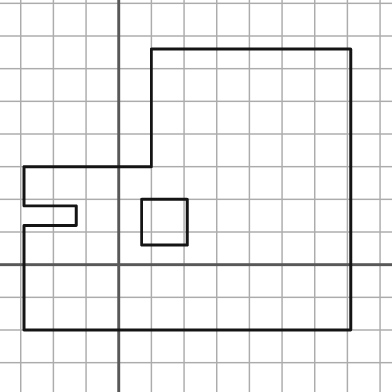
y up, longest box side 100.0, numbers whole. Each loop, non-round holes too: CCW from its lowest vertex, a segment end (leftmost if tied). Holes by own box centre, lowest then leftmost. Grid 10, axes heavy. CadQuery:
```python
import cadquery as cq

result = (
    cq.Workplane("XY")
    .moveTo(-29.0, -20.0)
    .lineTo(71.0, -20.0)
    .lineTo(71.0, 66.0)
    .lineTo(10.0, 66.0)
    .lineTo(10.0, 30.0)
    .lineTo(-29.0, 30.0)
    .lineTo(-29.0, 18.0)
    .lineTo(-13.0, 18.0)
    .lineTo(-13.0, 12.0)
    .lineTo(-29.0, 12.0)
    .close()
    .moveTo(7.0, 6.0)
    .lineTo(21.0, 6.0)
    .lineTo(21.0, 20.0)
    .lineTo(7.0, 20.0)
    .close()
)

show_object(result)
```